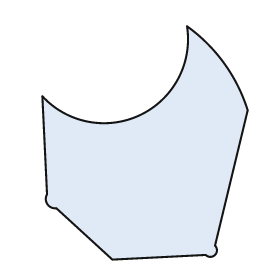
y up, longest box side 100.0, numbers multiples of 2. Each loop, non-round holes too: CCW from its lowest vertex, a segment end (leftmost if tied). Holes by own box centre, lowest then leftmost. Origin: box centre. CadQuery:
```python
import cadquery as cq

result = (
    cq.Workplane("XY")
    .moveTo(-14.0, -50.0)
    .lineTo(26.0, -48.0)
    .threePointArc((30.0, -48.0), (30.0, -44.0))
    .lineTo(44.0, 14.0)
    .threePointArc((34.0, 34.0), (18.0, 50.0))
    .threePointArc((-2.0, 12.0), (-44.0, 20.0))
    .lineTo(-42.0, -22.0)
    .threePointArc((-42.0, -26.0), (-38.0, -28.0))
    .close()
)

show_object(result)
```